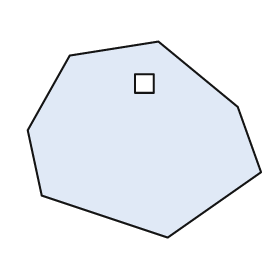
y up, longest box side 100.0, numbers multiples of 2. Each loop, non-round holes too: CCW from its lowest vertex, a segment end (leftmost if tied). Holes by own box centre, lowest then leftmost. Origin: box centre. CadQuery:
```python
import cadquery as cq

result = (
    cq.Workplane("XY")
    .moveTo(10.0, -42.0)
    .lineTo(50.0, -14.0)
    .lineTo(40.0, 14.0)
    .lineTo(6.0, 42.0)
    .lineTo(-32.0, 36.0)
    .lineTo(-50.0, 4.0)
    .lineTo(-44.0, -24.0)
    .close()
    .moveTo(-4.0, 20.0)
    .lineTo(4.0, 20.0)
    .lineTo(4.0, 28.0)
    .lineTo(-4.0, 28.0)
    .close()
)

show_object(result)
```